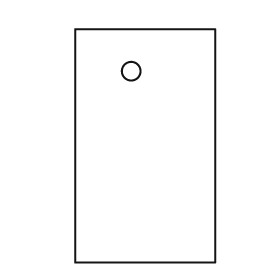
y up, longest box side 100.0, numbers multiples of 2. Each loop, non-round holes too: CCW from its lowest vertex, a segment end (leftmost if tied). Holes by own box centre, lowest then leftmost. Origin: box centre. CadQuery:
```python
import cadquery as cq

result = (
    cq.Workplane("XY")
    .moveTo(-30.0, -50.0)
    .lineTo(30.0, -50.0)
    .lineTo(30.0, 50.0)
    .lineTo(-30.0, 50.0)
    .close()
    .moveTo(-6.0, 32.0)
    .circle(4.0)
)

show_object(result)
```